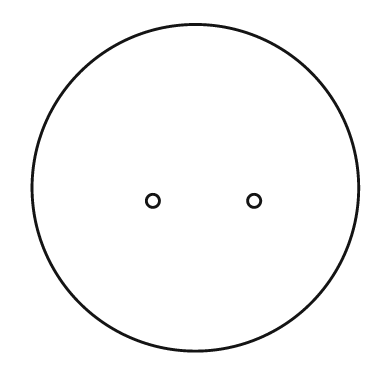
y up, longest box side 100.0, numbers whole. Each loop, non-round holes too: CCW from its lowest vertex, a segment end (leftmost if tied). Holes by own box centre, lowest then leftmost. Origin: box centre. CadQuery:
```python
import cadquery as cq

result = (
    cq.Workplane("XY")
    .moveTo(0.0, 0.0)
    .circle(50.0)
    .moveTo(-13.0, -4.0)
    .circle(2.0)
    .moveTo(18.0, -4.0)
    .circle(2.0)
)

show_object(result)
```